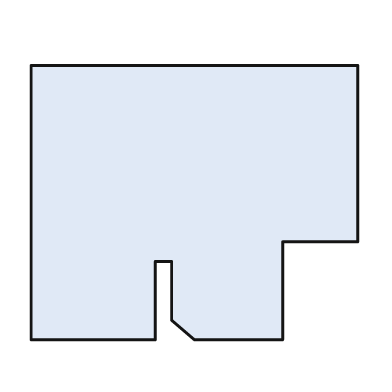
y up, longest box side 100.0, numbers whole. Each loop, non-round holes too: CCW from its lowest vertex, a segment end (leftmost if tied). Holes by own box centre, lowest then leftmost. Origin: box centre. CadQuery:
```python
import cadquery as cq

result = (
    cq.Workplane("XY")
    .moveTo(-50.0, -42.0)
    .lineTo(-12.0, -42.0)
    .lineTo(-12.0, -18.0)
    .lineTo(-7.0, -18.0)
    .lineTo(-7.0, -36.0)
    .lineTo(0.0, -42.0)
    .lineTo(27.0, -42.0)
    .lineTo(27.0, -12.0)
    .lineTo(50.0, -12.0)
    .lineTo(50.0, 42.0)
    .lineTo(-50.0, 42.0)
    .close()
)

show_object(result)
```